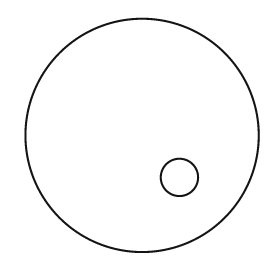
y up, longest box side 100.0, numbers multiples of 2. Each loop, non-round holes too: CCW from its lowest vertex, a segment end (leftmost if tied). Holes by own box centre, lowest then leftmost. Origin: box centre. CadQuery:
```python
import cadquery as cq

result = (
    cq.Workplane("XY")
    .moveTo(0.0, 0.0)
    .circle(50.0)
    .moveTo(16.0, -18.0)
    .circle(8.0)
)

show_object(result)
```